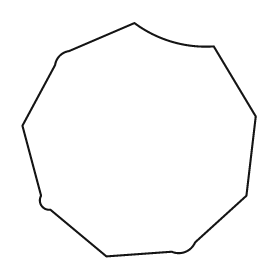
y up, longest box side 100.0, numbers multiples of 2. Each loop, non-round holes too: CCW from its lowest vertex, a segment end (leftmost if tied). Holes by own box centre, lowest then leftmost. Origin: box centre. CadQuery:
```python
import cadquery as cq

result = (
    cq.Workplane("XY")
    .moveTo(-14.0, -50.0)
    .lineTo(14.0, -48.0)
    .threePointArc((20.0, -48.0), (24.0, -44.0))
    .lineTo(46.0, -24.0)
    .lineTo(50.0, 10.0)
    .lineTo(32.0, 40.0)
    .threePointArc((14.0, 42.0), (-2.0, 50.0))
    .lineTo(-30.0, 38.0)
    .threePointArc((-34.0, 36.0), (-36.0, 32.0))
    .lineTo(-50.0, 6.0)
    .lineTo(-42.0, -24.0)
    .threePointArc((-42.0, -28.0), (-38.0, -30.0))
    .close()
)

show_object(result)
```